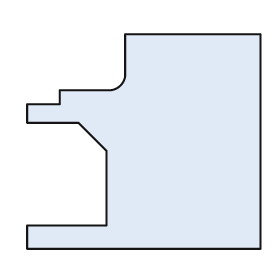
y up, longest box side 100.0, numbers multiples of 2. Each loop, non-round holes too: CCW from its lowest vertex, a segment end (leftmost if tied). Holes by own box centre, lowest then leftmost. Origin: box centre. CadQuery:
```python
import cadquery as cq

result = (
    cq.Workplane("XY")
    .moveTo(-50.0, -46.0)
    .lineTo(50.0, -46.0)
    .lineTo(50.0, 46.0)
    .lineTo(-8.0, 46.0)
    .lineTo(-8.0, 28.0)
    .threePointArc((-10.0, 24.0), (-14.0, 22.0))
    .lineTo(-36.0, 22.0)
    .lineTo(-36.0, 16.0)
    .lineTo(-50.0, 16.0)
    .lineTo(-50.0, 8.0)
    .lineTo(-28.0, 8.0)
    .lineTo(-16.0, -4.0)
    .lineTo(-16.0, -36.0)
    .lineTo(-50.0, -36.0)
    .close()
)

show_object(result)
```